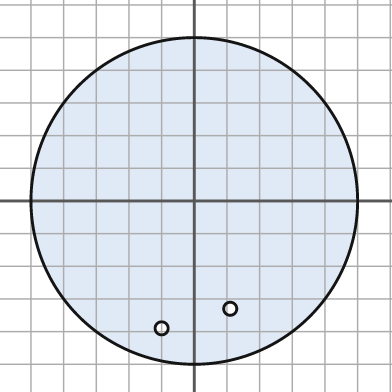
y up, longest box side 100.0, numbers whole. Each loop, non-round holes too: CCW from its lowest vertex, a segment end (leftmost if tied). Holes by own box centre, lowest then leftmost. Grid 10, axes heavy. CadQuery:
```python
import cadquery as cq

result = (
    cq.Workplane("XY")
    .moveTo(0.0, 0.0)
    .circle(50.0)
    .moveTo(-10.0, -39.0)
    .circle(2.0)
    .moveTo(11.0, -33.0)
    .circle(2.0)
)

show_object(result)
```